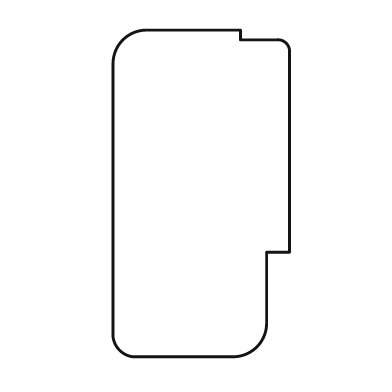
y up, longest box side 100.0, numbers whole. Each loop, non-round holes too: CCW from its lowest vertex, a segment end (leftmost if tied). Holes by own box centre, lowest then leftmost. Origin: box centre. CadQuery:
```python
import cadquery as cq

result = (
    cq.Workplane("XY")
    .moveTo(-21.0, -50.0)
    .lineTo(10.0, -50.0)
    .threePointArc((17.0, -47.0), (20.0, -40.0))
    .lineTo(20.0, -18.0)
    .lineTo(27.0, -18.0)
    .lineTo(27.0, 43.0)
    .threePointArc((26.0, 46.0), (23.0, 47.0))
    .lineTo(12.0, 47.0)
    .lineTo(12.0, 50.0)
    .lineTo(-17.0, 50.0)
    .threePointArc((-24.0, 47.0), (-27.0, 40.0))
    .lineTo(-27.0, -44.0)
    .threePointArc((-25.0, -48.0), (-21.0, -50.0))
    .close()
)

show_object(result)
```